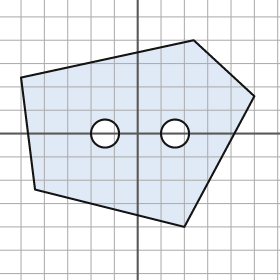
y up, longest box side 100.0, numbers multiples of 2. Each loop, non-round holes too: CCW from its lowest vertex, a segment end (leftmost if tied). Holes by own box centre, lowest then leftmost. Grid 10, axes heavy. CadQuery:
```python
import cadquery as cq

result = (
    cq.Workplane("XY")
    .moveTo(20.0, -40.0)
    .lineTo(50.0, 16.0)
    .lineTo(24.0, 40.0)
    .lineTo(-50.0, 24.0)
    .lineTo(-44.0, -24.0)
    .close()
    .moveTo(-14.0, 0.0)
    .circle(6.0)
    .moveTo(16.0, 0.0)
    .circle(6.0)
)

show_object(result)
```